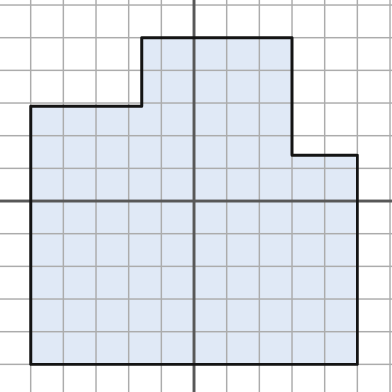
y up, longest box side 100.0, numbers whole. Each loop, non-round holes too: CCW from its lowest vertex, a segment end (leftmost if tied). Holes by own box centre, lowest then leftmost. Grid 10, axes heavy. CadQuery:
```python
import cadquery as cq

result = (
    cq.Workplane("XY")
    .moveTo(-50.0, -50.0)
    .lineTo(50.0, -50.0)
    .lineTo(50.0, 14.0)
    .lineTo(30.0, 14.0)
    .lineTo(30.0, 50.0)
    .lineTo(-16.0, 50.0)
    .lineTo(-16.0, 29.0)
    .lineTo(-50.0, 29.0)
    .close()
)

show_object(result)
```